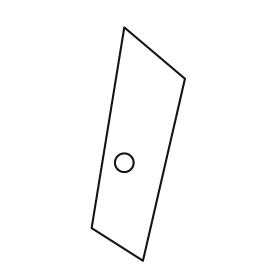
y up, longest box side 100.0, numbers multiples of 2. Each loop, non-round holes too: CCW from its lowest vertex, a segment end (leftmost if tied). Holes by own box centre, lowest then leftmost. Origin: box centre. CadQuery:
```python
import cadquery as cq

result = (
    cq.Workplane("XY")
    .moveTo(2.0, -50.0)
    .lineTo(20.0, 28.0)
    .lineTo(-6.0, 50.0)
    .lineTo(-20.0, -36.0)
    .close()
    .moveTo(-6.0, -8.0)
    .circle(4.0)
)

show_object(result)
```